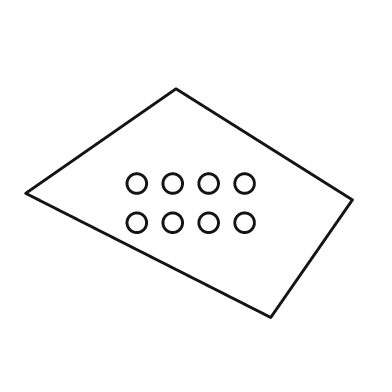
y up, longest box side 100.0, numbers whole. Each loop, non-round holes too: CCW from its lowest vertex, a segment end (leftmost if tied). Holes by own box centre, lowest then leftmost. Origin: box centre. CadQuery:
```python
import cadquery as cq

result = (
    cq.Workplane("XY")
    .moveTo(25.0, -35.0)
    .lineTo(50.0, 1.0)
    .lineTo(-4.0, 35.0)
    .lineTo(-50.0, 3.0)
    .close()
    .moveTo(-16.0, -6.0)
    .circle(3.0)
    .moveTo(-5.0, -6.0)
    .circle(3.0)
    .moveTo(6.0, -6.0)
    .circle(3.0)
    .moveTo(17.0, -6.0)
    .circle(3.0)
    .moveTo(-16.0, 6.0)
    .circle(3.0)
    .moveTo(-5.0, 6.0)
    .circle(3.0)
    .moveTo(6.0, 6.0)
    .circle(3.0)
    .moveTo(17.0, 6.0)
    .circle(3.0)
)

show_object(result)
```